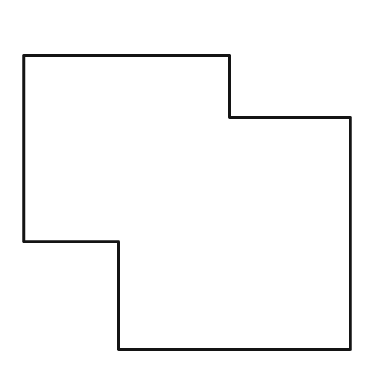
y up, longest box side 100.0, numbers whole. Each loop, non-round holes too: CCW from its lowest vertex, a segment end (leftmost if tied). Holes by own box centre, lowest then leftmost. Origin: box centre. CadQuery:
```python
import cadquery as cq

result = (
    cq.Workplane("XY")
    .moveTo(-21.0, -45.0)
    .lineTo(50.0, -45.0)
    .lineTo(50.0, 26.0)
    .lineTo(13.0, 26.0)
    .lineTo(13.0, 45.0)
    .lineTo(-50.0, 45.0)
    .lineTo(-50.0, -12.0)
    .lineTo(-21.0, -12.0)
    .close()
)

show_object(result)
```